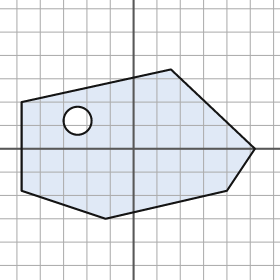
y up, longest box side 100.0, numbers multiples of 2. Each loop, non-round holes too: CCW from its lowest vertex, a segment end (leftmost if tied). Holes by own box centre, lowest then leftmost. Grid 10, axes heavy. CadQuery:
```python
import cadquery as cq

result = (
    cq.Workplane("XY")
    .moveTo(-12.0, -30.0)
    .lineTo(40.0, -18.0)
    .lineTo(52.0, 0.0)
    .lineTo(16.0, 34.0)
    .lineTo(-48.0, 20.0)
    .lineTo(-48.0, -18.0)
    .close()
    .moveTo(-24.0, 12.0)
    .circle(6.0)
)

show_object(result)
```